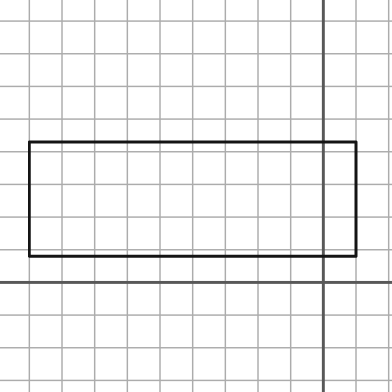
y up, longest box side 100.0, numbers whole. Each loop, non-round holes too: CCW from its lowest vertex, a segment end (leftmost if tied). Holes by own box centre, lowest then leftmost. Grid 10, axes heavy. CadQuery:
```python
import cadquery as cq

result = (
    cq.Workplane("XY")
    .moveTo(-90.0, 8.0)
    .lineTo(10.0, 8.0)
    .lineTo(10.0, 43.0)
    .lineTo(-90.0, 43.0)
    .close()
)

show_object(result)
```